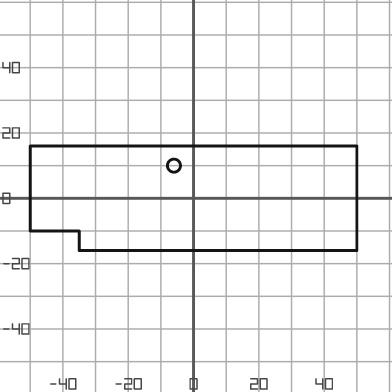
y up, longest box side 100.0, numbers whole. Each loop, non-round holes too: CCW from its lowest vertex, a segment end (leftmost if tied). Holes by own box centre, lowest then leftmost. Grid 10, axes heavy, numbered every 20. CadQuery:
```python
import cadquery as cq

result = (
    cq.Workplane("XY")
    .moveTo(-35.0, -16.0)
    .lineTo(50.0, -16.0)
    .lineTo(50.0, 16.0)
    .lineTo(-50.0, 16.0)
    .lineTo(-50.0, -10.0)
    .lineTo(-35.0, -10.0)
    .close()
    .moveTo(-6.0, 10.0)
    .circle(2.0)
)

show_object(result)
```